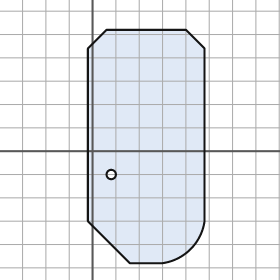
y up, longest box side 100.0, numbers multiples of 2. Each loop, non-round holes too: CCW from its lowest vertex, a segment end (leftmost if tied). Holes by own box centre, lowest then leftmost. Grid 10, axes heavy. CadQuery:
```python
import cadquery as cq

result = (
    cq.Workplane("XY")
    .moveTo(16.0, -48.0)
    .lineTo(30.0, -48.0)
    .threePointArc((42.0, -42.0), (48.0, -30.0))
    .lineTo(48.0, 44.0)
    .lineTo(40.0, 52.0)
    .lineTo(6.0, 52.0)
    .lineTo(-2.0, 44.0)
    .lineTo(-2.0, -30.0)
    .close()
    .moveTo(8.0, -10.0)
    .circle(2.0)
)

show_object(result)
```